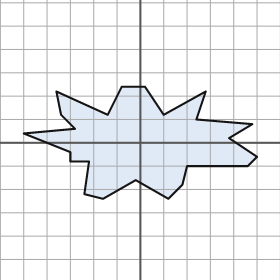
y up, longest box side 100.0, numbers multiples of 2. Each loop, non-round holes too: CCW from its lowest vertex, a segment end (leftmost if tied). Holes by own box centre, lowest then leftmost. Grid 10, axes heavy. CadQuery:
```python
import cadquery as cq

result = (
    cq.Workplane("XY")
    .moveTo(-16.0, -24.0)
    .lineTo(-2.0, -16.0)
    .lineTo(12.0, -24.0)
    .lineTo(18.0, -18.0)
    .lineTo(20.0, -10.0)
    .lineTo(46.0, -10.0)
    .lineTo(50.0, -6.0)
    .lineTo(38.0, 2.0)
    .lineTo(48.0, 8.0)
    .lineTo(24.0, 10.0)
    .lineTo(28.0, 22.0)
    .lineTo(10.0, 12.0)
    .lineTo(2.0, 24.0)
    .lineTo(-8.0, 24.0)
    .lineTo(-14.0, 12.0)
    .lineTo(-36.0, 22.0)
    .lineTo(-34.0, 12.0)
    .lineTo(-28.0, 6.0)
    .lineTo(-50.0, 4.0)
    .lineTo(-30.0, -4.0)
    .lineTo(-30.0, -8.0)
    .lineTo(-22.0, -8.0)
    .lineTo(-24.0, -22.0)
    .close()
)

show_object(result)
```